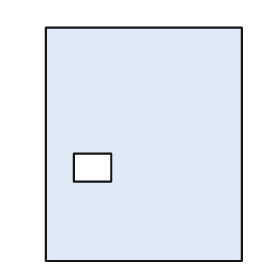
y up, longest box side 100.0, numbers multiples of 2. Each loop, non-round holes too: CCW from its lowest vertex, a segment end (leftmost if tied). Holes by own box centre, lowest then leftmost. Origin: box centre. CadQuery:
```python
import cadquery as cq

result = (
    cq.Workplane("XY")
    .moveTo(-42.0, -50.0)
    .lineTo(42.0, -50.0)
    .lineTo(42.0, 50.0)
    .lineTo(-42.0, 50.0)
    .close()
    .moveTo(-30.0, -16.0)
    .lineTo(-14.0, -16.0)
    .lineTo(-14.0, -4.0)
    .lineTo(-30.0, -4.0)
    .close()
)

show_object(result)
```